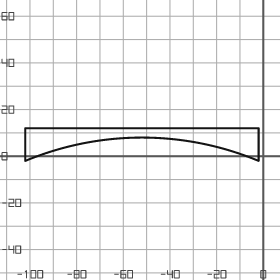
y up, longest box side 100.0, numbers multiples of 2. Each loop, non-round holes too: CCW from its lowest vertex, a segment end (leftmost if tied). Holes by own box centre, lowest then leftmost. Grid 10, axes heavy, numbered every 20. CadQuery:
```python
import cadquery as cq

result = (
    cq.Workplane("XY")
    .moveTo(-102.0, -2.0)
    .threePointArc((-52.0, 8.0), (-2.0, -2.0))
    .lineTo(-2.0, 12.0)
    .lineTo(-102.0, 12.0)
    .close()
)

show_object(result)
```